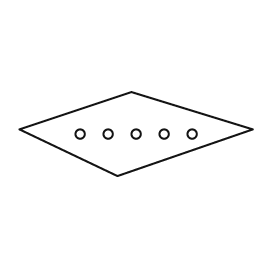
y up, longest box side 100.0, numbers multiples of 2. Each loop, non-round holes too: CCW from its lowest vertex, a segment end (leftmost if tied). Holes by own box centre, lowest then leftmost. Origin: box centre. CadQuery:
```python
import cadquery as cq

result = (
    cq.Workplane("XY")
    .moveTo(-8.0, -18.0)
    .lineTo(50.0, 2.0)
    .lineTo(-2.0, 18.0)
    .lineTo(-50.0, 2.0)
    .close()
    .moveTo(-24.0, 0.0)
    .circle(2.0)
    .moveTo(-12.0, 0.0)
    .circle(2.0)
    .moveTo(0.0, 0.0)
    .circle(2.0)
    .moveTo(12.0, 0.0)
    .circle(2.0)
    .moveTo(24.0, 0.0)
    .circle(2.0)
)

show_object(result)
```